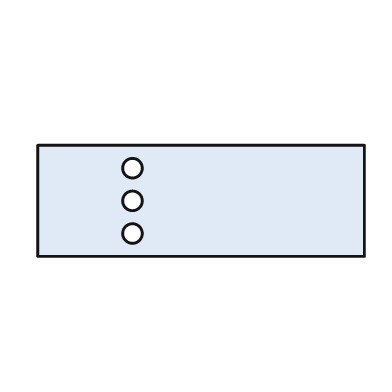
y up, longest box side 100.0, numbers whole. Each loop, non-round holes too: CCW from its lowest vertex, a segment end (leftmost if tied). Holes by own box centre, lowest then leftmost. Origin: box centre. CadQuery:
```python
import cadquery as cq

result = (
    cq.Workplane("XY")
    .moveTo(-50.0, -17.0)
    .lineTo(50.0, -17.0)
    .lineTo(50.0, 17.0)
    .lineTo(-50.0, 17.0)
    .close()
    .moveTo(-21.0, -10.0)
    .circle(3.0)
    .moveTo(-21.0, 0.0)
    .circle(3.0)
    .moveTo(-21.0, 10.0)
    .circle(3.0)
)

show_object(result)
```